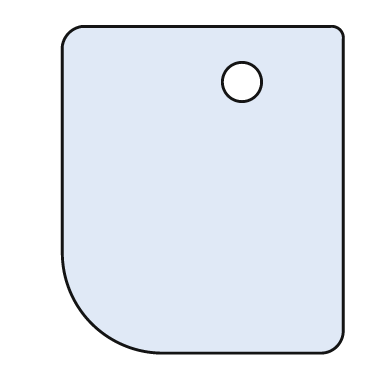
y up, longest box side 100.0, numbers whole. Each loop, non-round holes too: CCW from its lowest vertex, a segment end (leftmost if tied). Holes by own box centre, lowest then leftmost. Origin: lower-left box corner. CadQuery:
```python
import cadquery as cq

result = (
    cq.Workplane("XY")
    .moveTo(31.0, 0.0)
    .lineTo(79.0, 0.0)
    .threePointArc((84.0, 2.0), (86.0, 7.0))
    .lineTo(86.0, 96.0)
    .threePointArc((85.0, 99.0), (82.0, 100.0))
    .lineTo(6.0, 100.0)
    .threePointArc((2.0, 98.0), (0.0, 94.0))
    .lineTo(0.0, 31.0)
    .threePointArc((9.0, 9.0), (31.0, 0.0))
    .close()
    .moveTo(55.0, 83.0)
    .circle(6.0)
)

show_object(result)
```